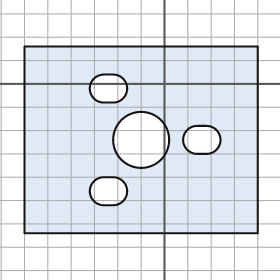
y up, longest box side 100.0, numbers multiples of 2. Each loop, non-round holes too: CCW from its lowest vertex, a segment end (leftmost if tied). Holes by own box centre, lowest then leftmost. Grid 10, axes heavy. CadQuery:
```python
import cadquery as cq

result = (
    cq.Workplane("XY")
    .moveTo(-60.0, -64.0)
    .lineTo(40.0, -64.0)
    .lineTo(40.0, 16.0)
    .lineTo(-60.0, 16.0)
    .close()
    .moveTo(-26.0, -52.0)
    .lineTo(-22.0, -52.0)
    .threePointArc((-16.0, -46.0), (-22.0, -40.0))
    .lineTo(-26.0, -40.0)
    .threePointArc((-32.0, -46.0), (-26.0, -52.0))
    .close()
    .moveTo(-10.0, -24.0)
    .circle(12.0)
    .moveTo(14.0, -30.0)
    .lineTo(18.0, -30.0)
    .threePointArc((24.0, -24.0), (18.0, -18.0))
    .lineTo(14.0, -18.0)
    .threePointArc((8.0, -24.0), (14.0, -30.0))
    .close()
    .moveTo(-26.0, -8.0)
    .lineTo(-22.0, -8.0)
    .threePointArc((-16.0, -2.0), (-22.0, 4.0))
    .lineTo(-26.0, 4.0)
    .threePointArc((-32.0, -2.0), (-26.0, -8.0))
    .close()
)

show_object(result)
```